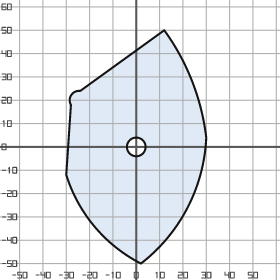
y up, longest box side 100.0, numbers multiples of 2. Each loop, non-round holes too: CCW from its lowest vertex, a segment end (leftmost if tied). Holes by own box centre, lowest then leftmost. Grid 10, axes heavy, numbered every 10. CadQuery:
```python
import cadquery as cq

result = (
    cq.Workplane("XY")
    .moveTo(2.0, -50.0)
    .threePointArc((22.0, -26.0), (30.0, 4.0))
    .threePointArc((24.0, 28.0), (12.0, 50.0))
    .lineTo(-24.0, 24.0)
    .threePointArc((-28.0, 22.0), (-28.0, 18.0))
    .lineTo(-30.0, -12.0)
    .threePointArc((-18.0, -34.0), (2.0, -50.0))
    .close()
    .moveTo(0.0, 0.0)
    .circle(4.0)
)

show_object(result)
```